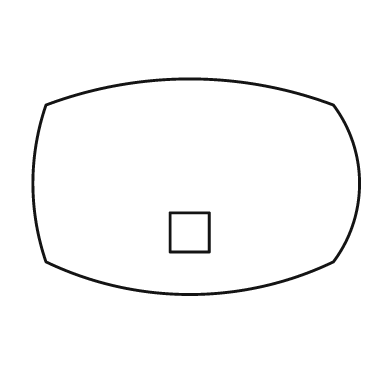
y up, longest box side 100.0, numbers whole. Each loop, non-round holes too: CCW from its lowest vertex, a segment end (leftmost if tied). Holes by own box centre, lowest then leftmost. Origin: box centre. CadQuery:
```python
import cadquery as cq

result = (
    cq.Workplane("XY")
    .moveTo(-46.0, -23.0)
    .threePointArc((-2.0, -33.0), (42.0, -23.0))
    .threePointArc((50.0, 1.0), (42.0, 25.0))
    .threePointArc((-2.0, 33.0), (-46.0, 25.0))
    .threePointArc((-50.0, 1.0), (-46.0, -23.0))
    .close()
    .moveTo(-8.0, -20.0)
    .lineTo(4.0, -20.0)
    .lineTo(4.0, -8.0)
    .lineTo(-8.0, -8.0)
    .close()
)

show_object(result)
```